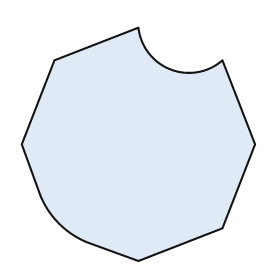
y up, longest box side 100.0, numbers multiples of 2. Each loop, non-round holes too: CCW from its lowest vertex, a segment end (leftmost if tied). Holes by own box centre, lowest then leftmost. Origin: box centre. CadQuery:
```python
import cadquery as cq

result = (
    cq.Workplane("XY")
    .moveTo(0.0, -50.0)
    .lineTo(36.0, -36.0)
    .lineTo(50.0, 0.0)
    .lineTo(36.0, 36.0)
    .threePointArc((14.0, 32.0), (0.0, 50.0))
    .lineTo(-36.0, 36.0)
    .lineTo(-50.0, 0.0)
    .lineTo(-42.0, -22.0)
    .threePointArc((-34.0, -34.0), (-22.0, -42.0))
    .close()
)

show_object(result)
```